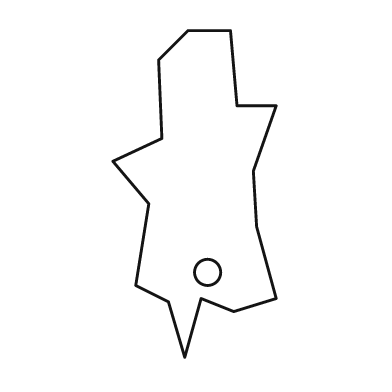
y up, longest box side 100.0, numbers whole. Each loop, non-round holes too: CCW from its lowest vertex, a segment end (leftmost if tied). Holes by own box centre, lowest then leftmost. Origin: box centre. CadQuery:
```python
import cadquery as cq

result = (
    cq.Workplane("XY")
    .moveTo(-3.0, -50.0)
    .lineTo(2.0, -32.0)
    .lineTo(12.0, -36.0)
    .lineTo(25.0, -32.0)
    .lineTo(19.0, -10.0)
    .lineTo(18.0, 7.0)
    .lineTo(25.0, 27.0)
    .lineTo(13.0, 27.0)
    .lineTo(11.0, 50.0)
    .lineTo(-2.0, 50.0)
    .lineTo(-11.0, 41.0)
    .lineTo(-10.0, 17.0)
    .lineTo(-25.0, 10.0)
    .lineTo(-14.0, -3.0)
    .lineTo(-18.0, -28.0)
    .lineTo(-8.0, -33.0)
    .close()
    .moveTo(4.0, -24.0)
    .circle(4.0)
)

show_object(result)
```